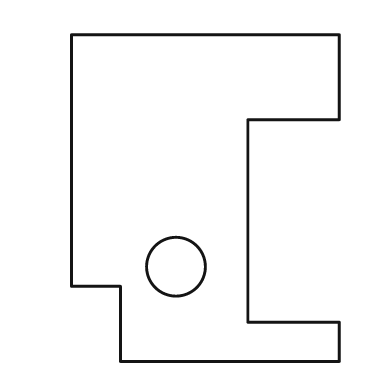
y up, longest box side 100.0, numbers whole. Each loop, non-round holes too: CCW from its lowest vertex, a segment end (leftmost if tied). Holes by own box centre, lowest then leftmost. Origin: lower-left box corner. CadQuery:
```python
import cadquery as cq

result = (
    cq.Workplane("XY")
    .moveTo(15.0, 0.0)
    .lineTo(82.0, 0.0)
    .lineTo(82.0, 12.0)
    .lineTo(54.0, 12.0)
    .lineTo(54.0, 74.0)
    .lineTo(82.0, 74.0)
    .lineTo(82.0, 100.0)
    .lineTo(0.0, 100.0)
    .lineTo(0.0, 23.0)
    .lineTo(15.0, 23.0)
    .close()
    .moveTo(32.0, 29.0)
    .circle(9.0)
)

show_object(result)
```